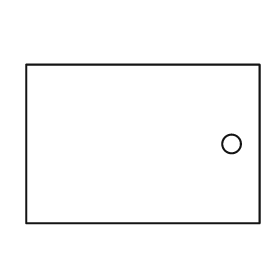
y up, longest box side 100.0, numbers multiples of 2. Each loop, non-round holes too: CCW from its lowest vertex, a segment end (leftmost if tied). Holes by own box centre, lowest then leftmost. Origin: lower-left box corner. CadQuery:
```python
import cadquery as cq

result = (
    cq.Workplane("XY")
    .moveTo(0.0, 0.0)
    .lineTo(100.0, 0.0)
    .lineTo(100.0, 68.0)
    .lineTo(0.0, 68.0)
    .close()
    .moveTo(88.0, 34.0)
    .circle(4.0)
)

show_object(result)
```